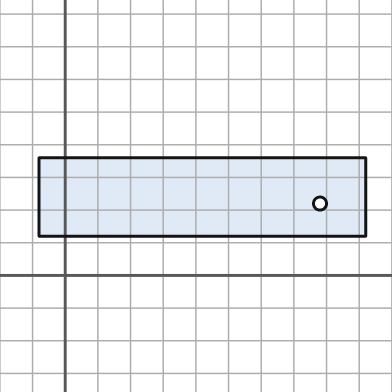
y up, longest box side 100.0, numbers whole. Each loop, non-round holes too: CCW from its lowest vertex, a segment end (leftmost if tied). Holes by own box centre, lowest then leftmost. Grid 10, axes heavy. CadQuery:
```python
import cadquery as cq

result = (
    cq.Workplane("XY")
    .moveTo(-8.0, 12.0)
    .lineTo(92.0, 12.0)
    .lineTo(92.0, 36.0)
    .lineTo(-8.0, 36.0)
    .close()
    .moveTo(78.0, 22.0)
    .circle(2.0)
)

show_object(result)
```